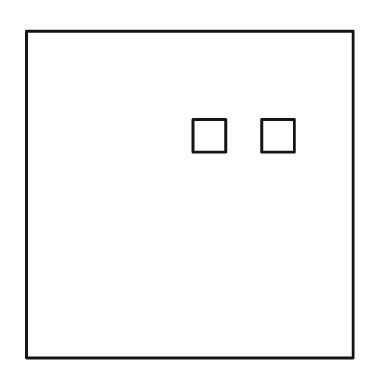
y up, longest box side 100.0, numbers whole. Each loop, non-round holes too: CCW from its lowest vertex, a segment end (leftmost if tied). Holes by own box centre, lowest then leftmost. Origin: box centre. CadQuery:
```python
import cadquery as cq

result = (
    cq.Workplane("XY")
    .moveTo(-50.0, -50.0)
    .lineTo(50.0, -50.0)
    .lineTo(50.0, 50.0)
    .lineTo(-50.0, 50.0)
    .close()
    .moveTo(1.0, 13.0)
    .lineTo(11.0, 13.0)
    .lineTo(11.0, 23.0)
    .lineTo(1.0, 23.0)
    .close()
    .moveTo(22.0, 13.0)
    .lineTo(32.0, 13.0)
    .lineTo(32.0, 23.0)
    .lineTo(22.0, 23.0)
    .close()
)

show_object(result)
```